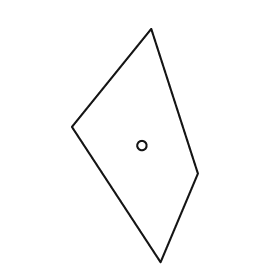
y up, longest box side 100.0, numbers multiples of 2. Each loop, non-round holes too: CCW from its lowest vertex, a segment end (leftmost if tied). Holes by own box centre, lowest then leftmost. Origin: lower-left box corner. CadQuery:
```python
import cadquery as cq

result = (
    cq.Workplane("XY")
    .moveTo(38.0, 0.0)
    .lineTo(54.0, 38.0)
    .lineTo(34.0, 100.0)
    .lineTo(0.0, 58.0)
    .close()
    .moveTo(30.0, 50.0)
    .circle(2.0)
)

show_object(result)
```